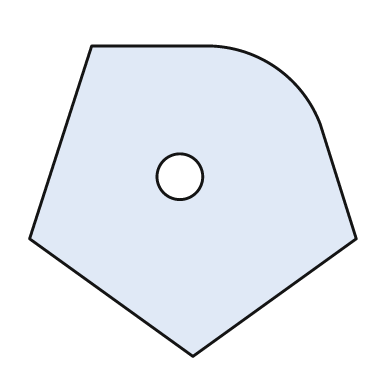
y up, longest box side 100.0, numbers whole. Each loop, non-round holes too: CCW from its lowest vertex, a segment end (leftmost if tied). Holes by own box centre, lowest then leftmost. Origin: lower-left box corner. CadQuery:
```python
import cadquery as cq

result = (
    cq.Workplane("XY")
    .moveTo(50.0, 0.0)
    .lineTo(100.0, 36.0)
    .lineTo(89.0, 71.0)
    .threePointArc((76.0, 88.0), (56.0, 95.0))
    .lineTo(19.0, 95.0)
    .lineTo(0.0, 36.0)
    .close()
    .moveTo(46.0, 55.0)
    .circle(7.0)
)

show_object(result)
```